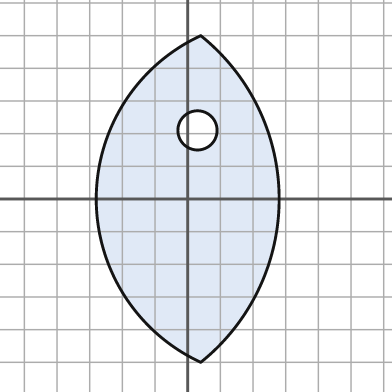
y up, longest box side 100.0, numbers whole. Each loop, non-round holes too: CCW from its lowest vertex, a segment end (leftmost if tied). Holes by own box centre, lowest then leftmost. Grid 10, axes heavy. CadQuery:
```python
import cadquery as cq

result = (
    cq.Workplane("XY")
    .moveTo(4.0, -50.0)
    .threePointArc((28.0, 0.0), (4.0, 50.0))
    .threePointArc((-28.0, 0.0), (4.0, -50.0))
    .close()
    .moveTo(3.0, 21.0)
    .circle(6.0)
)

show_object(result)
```